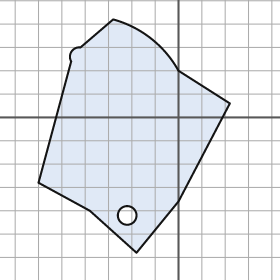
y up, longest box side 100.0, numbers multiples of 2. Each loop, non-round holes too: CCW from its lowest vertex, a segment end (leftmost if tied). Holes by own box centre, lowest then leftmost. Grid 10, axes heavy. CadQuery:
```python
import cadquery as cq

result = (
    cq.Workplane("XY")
    .moveTo(-18.0, -58.0)
    .lineTo(0.0, -36.0)
    .lineTo(22.0, 6.0)
    .lineTo(0.0, 20.0)
    .threePointArc((-12.0, 34.0), (-28.0, 42.0))
    .lineTo(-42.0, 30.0)
    .threePointArc((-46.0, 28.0), (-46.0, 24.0))
    .lineTo(-60.0, -28.0)
    .lineTo(-38.0, -40.0)
    .close()
    .moveTo(-22.0, -42.0)
    .circle(4.0)
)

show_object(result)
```